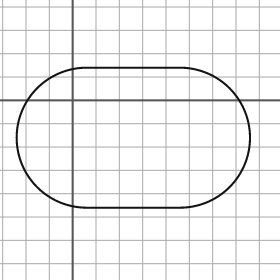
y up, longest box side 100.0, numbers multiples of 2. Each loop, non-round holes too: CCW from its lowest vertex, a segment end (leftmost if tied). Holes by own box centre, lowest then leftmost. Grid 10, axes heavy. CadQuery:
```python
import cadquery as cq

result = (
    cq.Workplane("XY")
    .moveTo(6.0, -46.0)
    .lineTo(46.0, -46.0)
    .threePointArc((76.0, -16.0), (46.0, 14.0))
    .lineTo(6.0, 14.0)
    .threePointArc((-24.0, -16.0), (6.0, -46.0))
    .close()
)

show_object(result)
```